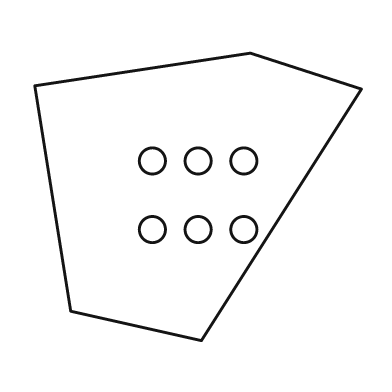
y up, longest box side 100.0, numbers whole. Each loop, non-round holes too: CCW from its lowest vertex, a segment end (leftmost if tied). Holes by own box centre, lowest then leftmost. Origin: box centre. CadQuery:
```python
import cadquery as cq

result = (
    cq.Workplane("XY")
    .moveTo(1.0, -44.0)
    .lineTo(50.0, 33.0)
    .lineTo(16.0, 44.0)
    .lineTo(-50.0, 34.0)
    .lineTo(-39.0, -35.0)
    .close()
    .moveTo(-14.0, -10.0)
    .circle(4.0)
    .moveTo(0.0, -10.0)
    .circle(4.0)
    .moveTo(14.0, -10.0)
    .circle(4.0)
    .moveTo(-14.0, 11.0)
    .circle(4.0)
    .moveTo(0.0, 11.0)
    .circle(4.0)
    .moveTo(14.0, 11.0)
    .circle(4.0)
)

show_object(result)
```